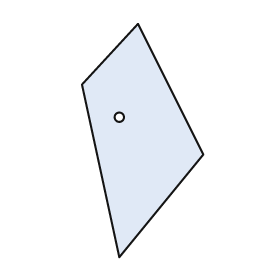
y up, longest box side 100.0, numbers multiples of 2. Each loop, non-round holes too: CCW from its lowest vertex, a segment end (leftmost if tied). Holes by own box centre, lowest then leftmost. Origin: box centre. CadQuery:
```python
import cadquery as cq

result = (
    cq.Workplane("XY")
    .moveTo(-10.0, -50.0)
    .lineTo(26.0, -6.0)
    .lineTo(-2.0, 50.0)
    .lineTo(-26.0, 24.0)
    .close()
    .moveTo(-10.0, 10.0)
    .circle(2.0)
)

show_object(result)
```